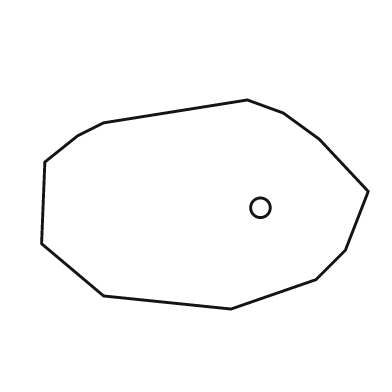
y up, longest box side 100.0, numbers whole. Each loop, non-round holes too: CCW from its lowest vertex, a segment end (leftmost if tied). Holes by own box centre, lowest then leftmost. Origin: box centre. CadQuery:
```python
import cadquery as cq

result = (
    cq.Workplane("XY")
    .moveTo(8.0, -32.0)
    .lineTo(34.0, -23.0)
    .lineTo(43.0, -14.0)
    .lineTo(50.0, 4.0)
    .lineTo(35.0, 20.0)
    .lineTo(24.0, 28.0)
    .lineTo(13.0, 32.0)
    .lineTo(-31.0, 25.0)
    .lineTo(-39.0, 21.0)
    .lineTo(-49.0, 13.0)
    .lineTo(-50.0, -12.0)
    .lineTo(-31.0, -28.0)
    .close()
    .moveTo(17.0, -1.0)
    .circle(3.0)
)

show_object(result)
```